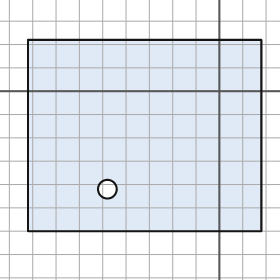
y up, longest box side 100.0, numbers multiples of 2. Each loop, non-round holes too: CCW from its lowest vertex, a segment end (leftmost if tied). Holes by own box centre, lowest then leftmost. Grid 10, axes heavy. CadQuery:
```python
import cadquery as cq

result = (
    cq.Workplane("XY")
    .moveTo(-82.0, -60.0)
    .lineTo(18.0, -60.0)
    .lineTo(18.0, 22.0)
    .lineTo(-82.0, 22.0)
    .close()
    .moveTo(-48.0, -42.0)
    .circle(4.0)
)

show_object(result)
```